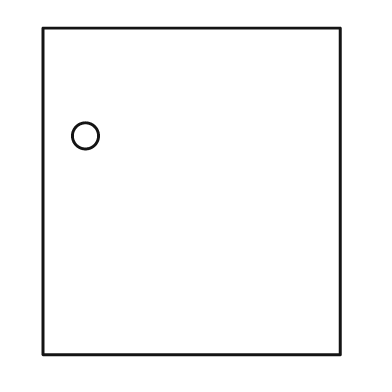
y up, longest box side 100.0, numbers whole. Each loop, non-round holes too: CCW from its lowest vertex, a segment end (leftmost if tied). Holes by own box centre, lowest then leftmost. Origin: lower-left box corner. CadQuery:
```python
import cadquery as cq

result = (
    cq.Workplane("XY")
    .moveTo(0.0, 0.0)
    .lineTo(91.0, 0.0)
    .lineTo(91.0, 100.0)
    .lineTo(0.0, 100.0)
    .close()
    .moveTo(13.0, 67.0)
    .circle(4.0)
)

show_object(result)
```